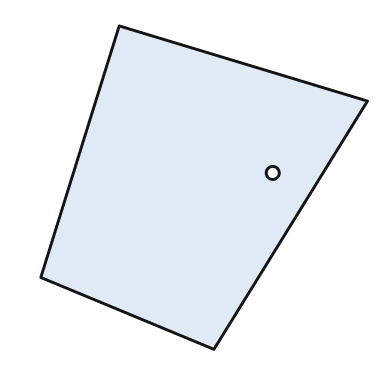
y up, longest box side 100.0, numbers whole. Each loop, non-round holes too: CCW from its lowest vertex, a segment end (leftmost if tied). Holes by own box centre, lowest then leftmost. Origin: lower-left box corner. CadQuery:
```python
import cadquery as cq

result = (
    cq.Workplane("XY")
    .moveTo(53.0, 0.0)
    .lineTo(100.0, 76.0)
    .lineTo(24.0, 99.0)
    .lineTo(0.0, 22.0)
    .close()
    .moveTo(71.0, 54.0)
    .circle(2.0)
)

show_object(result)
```